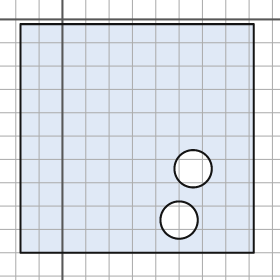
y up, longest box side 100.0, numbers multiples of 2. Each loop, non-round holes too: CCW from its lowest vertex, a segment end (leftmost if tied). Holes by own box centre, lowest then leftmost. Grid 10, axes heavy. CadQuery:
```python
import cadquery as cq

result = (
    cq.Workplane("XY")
    .moveTo(-18.0, -100.0)
    .lineTo(82.0, -100.0)
    .lineTo(82.0, -2.0)
    .lineTo(-18.0, -2.0)
    .close()
    .moveTo(50.0, -86.0)
    .circle(8.0)
    .moveTo(56.0, -64.0)
    .circle(8.0)
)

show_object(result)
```